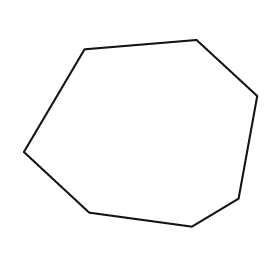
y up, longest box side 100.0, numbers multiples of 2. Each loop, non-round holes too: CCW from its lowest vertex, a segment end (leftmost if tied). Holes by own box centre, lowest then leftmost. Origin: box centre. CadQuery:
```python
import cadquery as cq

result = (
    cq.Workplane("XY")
    .moveTo(22.0, -40.0)
    .lineTo(42.0, -28.0)
    .lineTo(50.0, 16.0)
    .lineTo(24.0, 40.0)
    .lineTo(-24.0, 36.0)
    .lineTo(-50.0, -8.0)
    .lineTo(-22.0, -34.0)
    .close()
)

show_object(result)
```